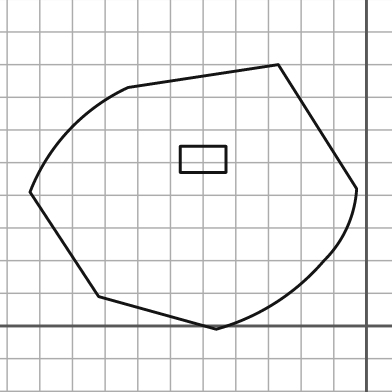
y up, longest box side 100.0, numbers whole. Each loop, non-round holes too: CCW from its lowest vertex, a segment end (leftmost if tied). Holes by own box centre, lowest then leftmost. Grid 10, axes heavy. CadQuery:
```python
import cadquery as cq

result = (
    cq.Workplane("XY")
    .moveTo(-46.0, -1.0)
    .threePointArc((-28.0, 7.0), (-13.0, 20.0))
    .threePointArc((-6.0, 30.0), (-3.0, 42.0))
    .lineTo(-27.0, 80.0)
    .lineTo(-73.0, 73.0)
    .threePointArc((-91.0, 60.0), (-103.0, 41.0))
    .lineTo(-82.0, 9.0)
    .close()
    .moveTo(-57.0, 47.0)
    .lineTo(-43.0, 47.0)
    .lineTo(-43.0, 55.0)
    .lineTo(-57.0, 55.0)
    .close()
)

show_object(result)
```